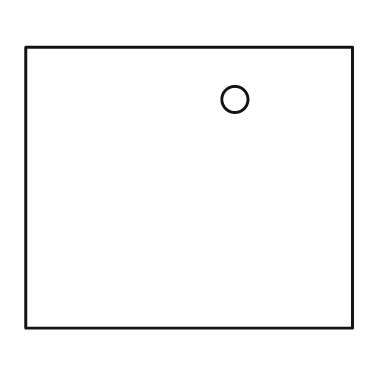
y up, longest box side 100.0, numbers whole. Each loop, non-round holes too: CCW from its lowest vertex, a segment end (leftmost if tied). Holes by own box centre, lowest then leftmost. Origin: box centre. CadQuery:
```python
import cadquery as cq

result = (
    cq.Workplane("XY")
    .moveTo(-50.0, -43.0)
    .lineTo(50.0, -43.0)
    .lineTo(50.0, 43.0)
    .lineTo(-50.0, 43.0)
    .close()
    .moveTo(14.0, 27.0)
    .circle(4.0)
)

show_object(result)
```